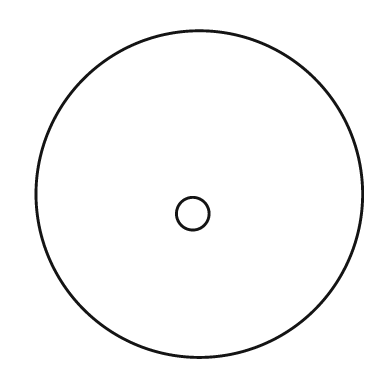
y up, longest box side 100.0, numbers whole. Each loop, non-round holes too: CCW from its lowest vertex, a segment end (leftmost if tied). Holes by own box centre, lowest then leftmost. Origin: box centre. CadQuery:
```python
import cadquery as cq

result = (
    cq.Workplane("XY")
    .moveTo(0.0, 0.0)
    .circle(50.0)
    .moveTo(-2.0, -6.0)
    .circle(5.0)
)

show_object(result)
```